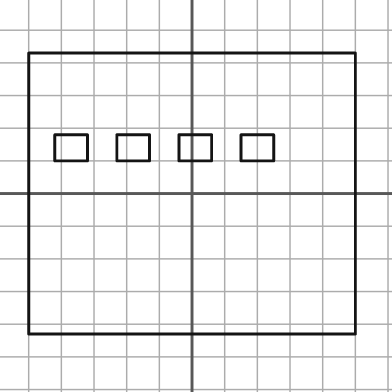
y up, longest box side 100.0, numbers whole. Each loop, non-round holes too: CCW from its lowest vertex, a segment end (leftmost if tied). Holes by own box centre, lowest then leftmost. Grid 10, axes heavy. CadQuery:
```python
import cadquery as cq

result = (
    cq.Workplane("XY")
    .moveTo(-50.0, -43.0)
    .lineTo(50.0, -43.0)
    .lineTo(50.0, 43.0)
    .lineTo(-50.0, 43.0)
    .close()
    .moveTo(-42.0, 10.0)
    .lineTo(-32.0, 10.0)
    .lineTo(-32.0, 18.0)
    .lineTo(-42.0, 18.0)
    .close()
    .moveTo(-23.0, 10.0)
    .lineTo(-13.0, 10.0)
    .lineTo(-13.0, 18.0)
    .lineTo(-23.0, 18.0)
    .close()
    .moveTo(-4.0, 10.0)
    .lineTo(6.0, 10.0)
    .lineTo(6.0, 18.0)
    .lineTo(-4.0, 18.0)
    .close()
    .moveTo(15.0, 10.0)
    .lineTo(25.0, 10.0)
    .lineTo(25.0, 18.0)
    .lineTo(15.0, 18.0)
    .close()
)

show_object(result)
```